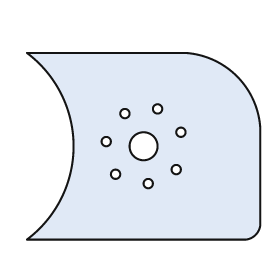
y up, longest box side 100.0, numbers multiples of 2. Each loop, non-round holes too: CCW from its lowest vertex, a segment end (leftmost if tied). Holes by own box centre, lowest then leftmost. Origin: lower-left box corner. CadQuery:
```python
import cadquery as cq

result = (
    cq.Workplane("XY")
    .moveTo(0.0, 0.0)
    .lineTo(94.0, 0.0)
    .threePointArc((98.0, 2.0), (100.0, 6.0))
    .lineTo(100.0, 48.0)
    .threePointArc((90.0, 70.0), (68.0, 80.0))
    .lineTo(0.0, 80.0)
    .threePointArc((20.0, 40.0), (0.0, 0.0))
    .close()
    .moveTo(52.0, 24.0)
    .circle(2.0)
    .moveTo(38.0, 28.0)
    .circle(2.0)
    .moveTo(64.0, 30.0)
    .circle(2.0)
    .moveTo(50.0, 40.0)
    .circle(6.0)
    .moveTo(34.0, 42.0)
    .circle(2.0)
    .moveTo(66.0, 46.0)
    .circle(2.0)
    .moveTo(42.0, 54.0)
    .circle(2.0)
    .moveTo(56.0, 56.0)
    .circle(2.0)
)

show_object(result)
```